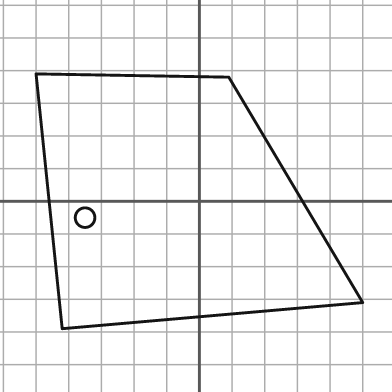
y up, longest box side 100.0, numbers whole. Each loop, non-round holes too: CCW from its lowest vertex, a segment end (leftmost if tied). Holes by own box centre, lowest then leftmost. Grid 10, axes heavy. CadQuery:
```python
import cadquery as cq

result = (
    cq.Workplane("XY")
    .moveTo(-42.0, -39.0)
    .lineTo(50.0, -31.0)
    .lineTo(9.0, 38.0)
    .lineTo(-50.0, 39.0)
    .close()
    .moveTo(-35.0, -5.0)
    .circle(3.0)
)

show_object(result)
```